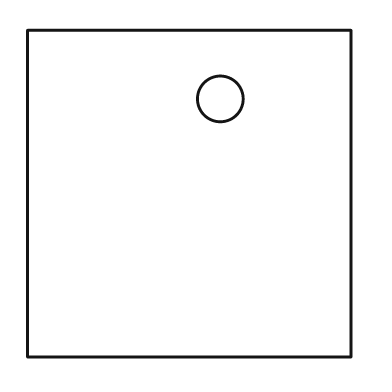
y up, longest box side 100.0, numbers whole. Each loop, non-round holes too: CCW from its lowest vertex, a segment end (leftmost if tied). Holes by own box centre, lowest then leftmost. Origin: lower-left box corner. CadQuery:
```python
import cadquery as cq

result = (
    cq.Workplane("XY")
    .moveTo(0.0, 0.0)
    .lineTo(99.0, 0.0)
    .lineTo(99.0, 100.0)
    .lineTo(0.0, 100.0)
    .close()
    .moveTo(59.0, 79.0)
    .circle(7.0)
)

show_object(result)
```